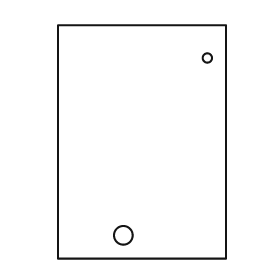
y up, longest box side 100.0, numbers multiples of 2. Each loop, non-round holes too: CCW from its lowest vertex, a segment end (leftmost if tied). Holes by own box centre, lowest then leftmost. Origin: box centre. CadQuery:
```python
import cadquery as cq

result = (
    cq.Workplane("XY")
    .moveTo(-36.0, -50.0)
    .lineTo(36.0, -50.0)
    .lineTo(36.0, 50.0)
    .lineTo(-36.0, 50.0)
    .close()
    .moveTo(-8.0, -40.0)
    .circle(4.0)
    .moveTo(28.0, 36.0)
    .circle(2.0)
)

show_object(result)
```